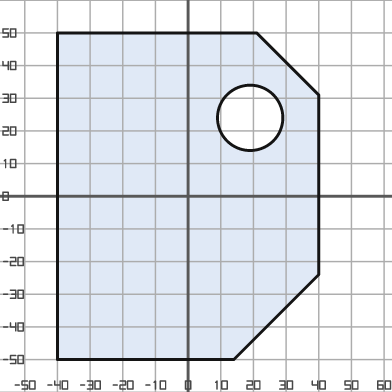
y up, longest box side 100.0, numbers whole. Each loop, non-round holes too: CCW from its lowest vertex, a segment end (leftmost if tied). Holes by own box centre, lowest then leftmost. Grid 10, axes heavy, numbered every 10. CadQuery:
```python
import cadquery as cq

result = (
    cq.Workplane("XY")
    .moveTo(-40.0, -50.0)
    .lineTo(14.0, -50.0)
    .lineTo(40.0, -24.0)
    .lineTo(40.0, 31.0)
    .lineTo(21.0, 50.0)
    .lineTo(-40.0, 50.0)
    .close()
    .moveTo(19.0, 24.0)
    .circle(10.0)
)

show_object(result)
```